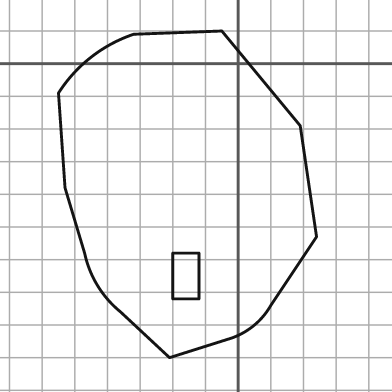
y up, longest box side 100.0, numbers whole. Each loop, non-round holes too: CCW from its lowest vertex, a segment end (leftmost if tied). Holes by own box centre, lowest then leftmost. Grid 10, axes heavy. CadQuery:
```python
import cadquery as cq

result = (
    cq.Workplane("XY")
    .moveTo(-21.0, -90.0)
    .lineTo(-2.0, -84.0)
    .threePointArc((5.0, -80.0), (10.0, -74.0))
    .lineTo(24.0, -53.0)
    .lineTo(19.0, -19.0)
    .lineTo(-5.0, 10.0)
    .lineTo(-32.0, 9.0)
    .threePointArc((-45.0, 2.0), (-55.0, -9.0))
    .lineTo(-53.0, -38.0)
    .lineTo(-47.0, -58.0)
    .threePointArc((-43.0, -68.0), (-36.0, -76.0))
    .close()
    .moveTo(-20.0, -72.0)
    .lineTo(-12.0, -72.0)
    .lineTo(-12.0, -58.0)
    .lineTo(-20.0, -58.0)
    .close()
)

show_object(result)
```